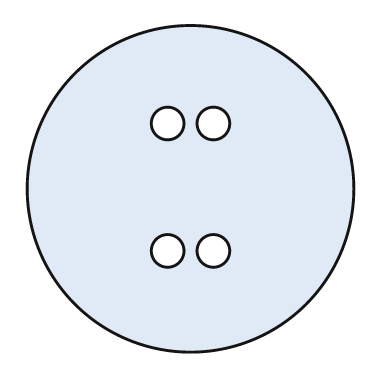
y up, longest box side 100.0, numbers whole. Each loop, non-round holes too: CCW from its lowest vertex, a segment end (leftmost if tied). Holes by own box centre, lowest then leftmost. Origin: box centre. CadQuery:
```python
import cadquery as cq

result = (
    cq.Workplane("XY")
    .moveTo(0.0, 0.0)
    .circle(50.0)
    .moveTo(-7.0, -19.0)
    .circle(5.0)
    .moveTo(7.0, -19.0)
    .circle(5.0)
    .moveTo(-7.0, 20.0)
    .circle(5.0)
    .moveTo(7.0, 20.0)
    .circle(5.0)
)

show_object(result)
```